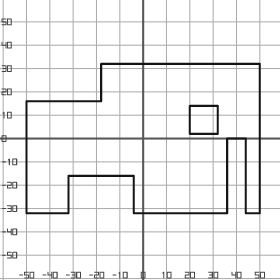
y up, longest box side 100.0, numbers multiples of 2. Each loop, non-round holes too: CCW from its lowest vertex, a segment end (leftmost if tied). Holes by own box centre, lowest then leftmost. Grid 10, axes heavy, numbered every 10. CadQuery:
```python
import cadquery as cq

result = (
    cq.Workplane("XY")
    .moveTo(-50.0, -32.0)
    .lineTo(-32.0, -32.0)
    .lineTo(-32.0, -16.0)
    .lineTo(-4.0, -16.0)
    .lineTo(-4.0, -32.0)
    .lineTo(36.0, -32.0)
    .lineTo(36.0, 0.0)
    .lineTo(44.0, 0.0)
    .lineTo(44.0, -32.0)
    .lineTo(50.0, -32.0)
    .lineTo(50.0, 32.0)
    .lineTo(-18.0, 32.0)
    .lineTo(-18.0, 16.0)
    .lineTo(-50.0, 16.0)
    .close()
    .moveTo(20.0, 2.0)
    .lineTo(32.0, 2.0)
    .lineTo(32.0, 14.0)
    .lineTo(20.0, 14.0)
    .close()
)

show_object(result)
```